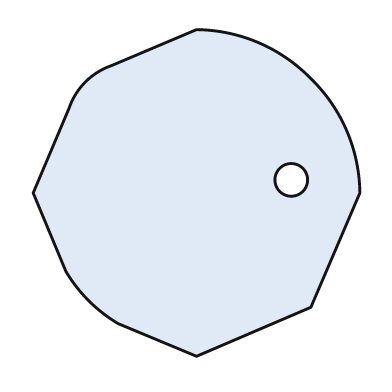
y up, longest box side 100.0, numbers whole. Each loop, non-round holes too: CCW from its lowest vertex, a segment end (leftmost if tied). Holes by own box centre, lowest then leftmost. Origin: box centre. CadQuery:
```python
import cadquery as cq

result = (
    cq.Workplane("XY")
    .moveTo(0.0, -50.0)
    .lineTo(35.0, -35.0)
    .lineTo(50.0, 0.0)
    .threePointArc((46.0, 19.0), (35.0, 35.0))
    .threePointArc((19.0, 46.0), (0.0, 50.0))
    .lineTo(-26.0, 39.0)
    .threePointArc((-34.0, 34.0), (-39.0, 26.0))
    .lineTo(-50.0, 0.0)
    .lineTo(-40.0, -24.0)
    .threePointArc((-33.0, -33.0), (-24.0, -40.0))
    .close()
    .moveTo(29.0, 4.0)
    .circle(5.0)
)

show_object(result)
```